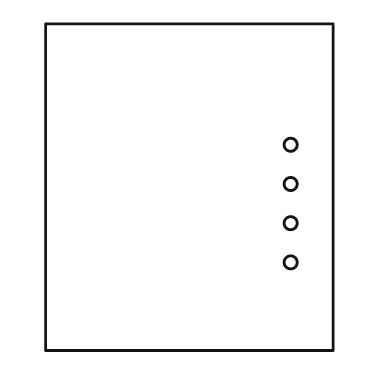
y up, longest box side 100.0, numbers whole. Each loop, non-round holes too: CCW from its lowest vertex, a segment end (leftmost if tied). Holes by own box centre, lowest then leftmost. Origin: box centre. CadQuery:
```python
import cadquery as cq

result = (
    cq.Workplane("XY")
    .moveTo(-44.0, -50.0)
    .lineTo(44.0, -50.0)
    .lineTo(44.0, 50.0)
    .lineTo(-44.0, 50.0)
    .close()
    .moveTo(31.0, -23.0)
    .circle(2.0)
    .moveTo(31.0, -11.0)
    .circle(2.0)
    .moveTo(31.0, 1.0)
    .circle(2.0)
    .moveTo(31.0, 13.0)
    .circle(2.0)
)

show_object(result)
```